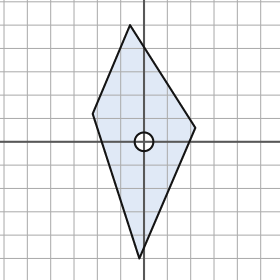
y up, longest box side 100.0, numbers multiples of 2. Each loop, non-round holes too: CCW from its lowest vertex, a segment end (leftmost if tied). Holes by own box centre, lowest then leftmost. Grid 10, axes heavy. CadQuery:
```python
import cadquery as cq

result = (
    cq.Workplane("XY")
    .moveTo(-2.0, -50.0)
    .lineTo(22.0, 6.0)
    .lineTo(-6.0, 50.0)
    .lineTo(-22.0, 12.0)
    .close()
    .moveTo(0.0, 0.0)
    .circle(4.0)
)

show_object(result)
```